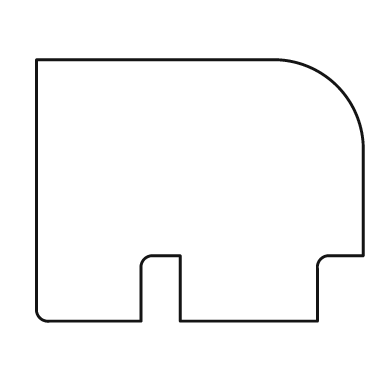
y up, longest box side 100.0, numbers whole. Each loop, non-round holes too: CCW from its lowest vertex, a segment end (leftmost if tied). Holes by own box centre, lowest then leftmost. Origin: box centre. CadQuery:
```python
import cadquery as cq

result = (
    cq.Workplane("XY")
    .moveTo(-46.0, -40.0)
    .lineTo(-18.0, -40.0)
    .lineTo(-18.0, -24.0)
    .threePointArc((-17.0, -21.0), (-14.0, -20.0))
    .lineTo(-6.0, -20.0)
    .lineTo(-6.0, -40.0)
    .lineTo(36.0, -40.0)
    .lineTo(36.0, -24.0)
    .threePointArc((37.0, -21.0), (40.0, -20.0))
    .lineTo(50.0, -20.0)
    .lineTo(50.0, 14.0)
    .threePointArc((42.0, 32.0), (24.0, 40.0))
    .lineTo(-50.0, 40.0)
    .lineTo(-50.0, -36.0)
    .threePointArc((-49.0, -39.0), (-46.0, -40.0))
    .close()
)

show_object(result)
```